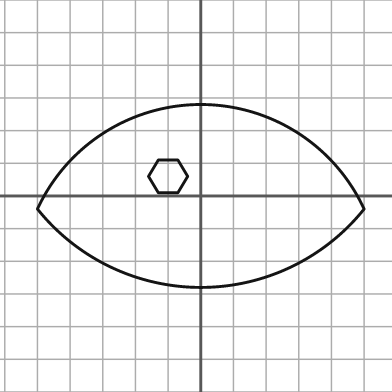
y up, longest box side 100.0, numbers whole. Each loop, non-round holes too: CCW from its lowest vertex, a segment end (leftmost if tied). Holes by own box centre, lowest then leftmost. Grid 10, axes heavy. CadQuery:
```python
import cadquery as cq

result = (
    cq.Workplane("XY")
    .moveTo(-50.0, -4.0)
    .threePointArc((0.0, -28.0), (50.0, -4.0))
    .threePointArc((0.0, 28.0), (-50.0, -4.0))
    .close()
    .moveTo(-13.0, 1.0)
    .lineTo(-7.0, 1.0)
    .lineTo(-4.0, 6.0)
    .lineTo(-7.0, 11.0)
    .lineTo(-13.0, 11.0)
    .lineTo(-16.0, 6.0)
    .close()
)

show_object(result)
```